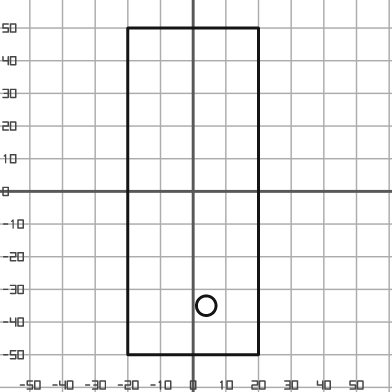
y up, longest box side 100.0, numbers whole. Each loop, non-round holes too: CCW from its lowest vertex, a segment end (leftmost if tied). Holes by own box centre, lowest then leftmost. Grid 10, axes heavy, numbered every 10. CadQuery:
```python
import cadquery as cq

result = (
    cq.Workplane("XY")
    .moveTo(-20.0, -50.0)
    .lineTo(20.0, -50.0)
    .lineTo(20.0, 50.0)
    .lineTo(-20.0, 50.0)
    .close()
    .moveTo(4.0, -35.0)
    .circle(3.0)
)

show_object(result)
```